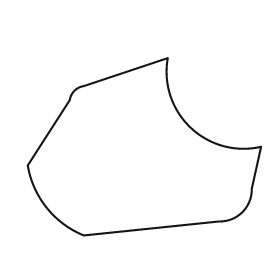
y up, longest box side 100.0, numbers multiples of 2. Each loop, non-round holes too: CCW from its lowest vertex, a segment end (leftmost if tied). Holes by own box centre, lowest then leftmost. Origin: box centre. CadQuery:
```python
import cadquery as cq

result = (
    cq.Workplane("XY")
    .moveTo(-26.0, -38.0)
    .lineTo(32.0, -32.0)
    .threePointArc((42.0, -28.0), (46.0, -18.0))
    .lineTo(50.0, 0.0)
    .threePointArc((20.0, 8.0), (10.0, 38.0))
    .lineTo(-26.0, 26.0)
    .threePointArc((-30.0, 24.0), (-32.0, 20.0))
    .lineTo(-50.0, -8.0)
    .threePointArc((-42.0, -26.0), (-26.0, -38.0))
    .close()
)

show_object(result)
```